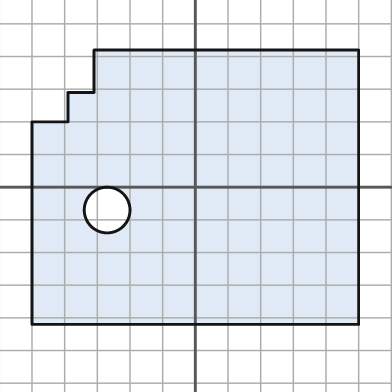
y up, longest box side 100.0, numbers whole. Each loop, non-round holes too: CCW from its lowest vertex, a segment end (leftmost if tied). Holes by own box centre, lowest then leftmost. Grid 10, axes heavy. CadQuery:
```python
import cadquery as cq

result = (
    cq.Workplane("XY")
    .moveTo(-50.0, -42.0)
    .lineTo(50.0, -42.0)
    .lineTo(50.0, 42.0)
    .lineTo(-31.0, 42.0)
    .lineTo(-31.0, 29.0)
    .lineTo(-39.0, 29.0)
    .lineTo(-39.0, 20.0)
    .lineTo(-50.0, 20.0)
    .close()
    .moveTo(-27.0, -7.0)
    .circle(7.0)
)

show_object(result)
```